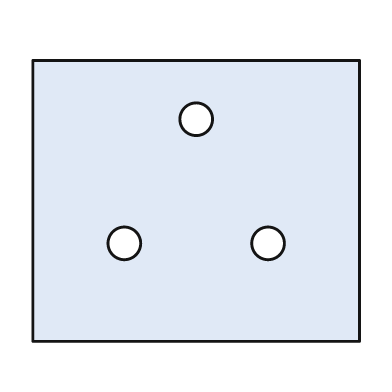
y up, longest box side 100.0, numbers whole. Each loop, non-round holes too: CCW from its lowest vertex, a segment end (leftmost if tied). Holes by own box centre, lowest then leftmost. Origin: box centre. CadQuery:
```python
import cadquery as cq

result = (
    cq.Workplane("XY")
    .moveTo(-50.0, -43.0)
    .lineTo(50.0, -43.0)
    .lineTo(50.0, 43.0)
    .lineTo(-50.0, 43.0)
    .close()
    .moveTo(-22.0, -13.0)
    .circle(5.0)
    .moveTo(22.0, -13.0)
    .circle(5.0)
    .moveTo(0.0, 25.0)
    .circle(5.0)
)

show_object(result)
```